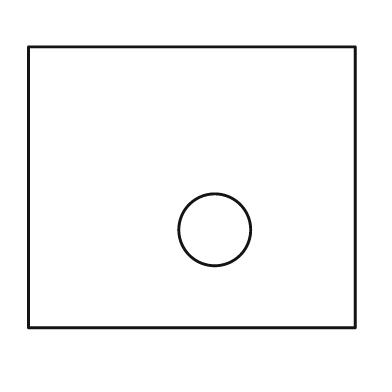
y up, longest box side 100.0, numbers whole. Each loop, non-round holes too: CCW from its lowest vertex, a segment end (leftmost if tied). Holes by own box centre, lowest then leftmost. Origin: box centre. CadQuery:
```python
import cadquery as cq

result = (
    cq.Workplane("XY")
    .moveTo(-50.0, -43.0)
    .lineTo(50.0, -43.0)
    .lineTo(50.0, 43.0)
    .lineTo(-50.0, 43.0)
    .close()
    .moveTo(7.0, -13.0)
    .circle(11.0)
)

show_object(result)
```